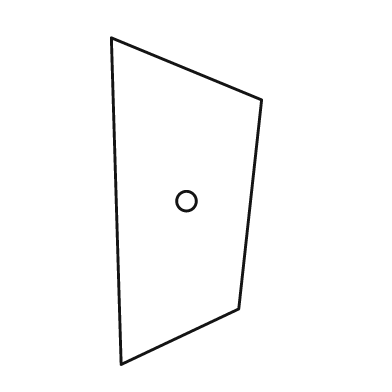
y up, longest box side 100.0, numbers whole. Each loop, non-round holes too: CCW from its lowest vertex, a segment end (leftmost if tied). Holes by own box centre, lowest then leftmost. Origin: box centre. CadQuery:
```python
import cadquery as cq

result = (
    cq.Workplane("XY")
    .moveTo(-20.0, -50.0)
    .lineTo(16.0, -33.0)
    .lineTo(23.0, 31.0)
    .lineTo(-23.0, 50.0)
    .close()
    .moveTo(0.0, 0.0)
    .circle(3.0)
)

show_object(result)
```